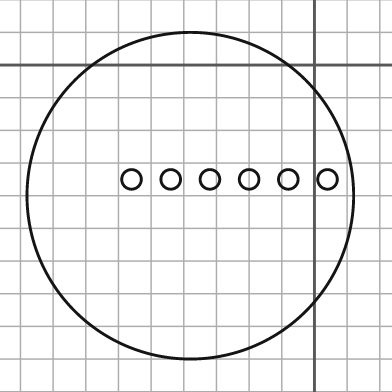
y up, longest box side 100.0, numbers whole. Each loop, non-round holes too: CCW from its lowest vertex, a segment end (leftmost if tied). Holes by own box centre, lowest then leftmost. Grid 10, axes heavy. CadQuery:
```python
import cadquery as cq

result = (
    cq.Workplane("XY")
    .moveTo(-38.0, -40.0)
    .circle(50.0)
    .moveTo(-56.0, -35.0)
    .circle(3.0)
    .moveTo(-44.0, -35.0)
    .circle(3.0)
    .moveTo(-32.0, -35.0)
    .circle(3.0)
    .moveTo(-20.0, -35.0)
    .circle(3.0)
    .moveTo(-8.0, -35.0)
    .circle(3.0)
    .moveTo(4.0, -35.0)
    .circle(3.0)
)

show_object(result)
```